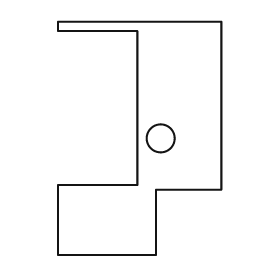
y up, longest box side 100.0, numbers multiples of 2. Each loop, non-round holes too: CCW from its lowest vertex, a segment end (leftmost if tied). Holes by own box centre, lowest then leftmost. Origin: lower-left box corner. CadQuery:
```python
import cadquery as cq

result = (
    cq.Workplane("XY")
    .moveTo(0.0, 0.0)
    .lineTo(42.0, 0.0)
    .lineTo(42.0, 28.0)
    .lineTo(70.0, 28.0)
    .lineTo(70.0, 100.0)
    .lineTo(0.0, 100.0)
    .lineTo(0.0, 96.0)
    .lineTo(34.0, 96.0)
    .lineTo(34.0, 30.0)
    .lineTo(0.0, 30.0)
    .close()
    .moveTo(44.0, 50.0)
    .circle(6.0)
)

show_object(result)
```